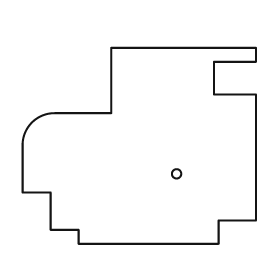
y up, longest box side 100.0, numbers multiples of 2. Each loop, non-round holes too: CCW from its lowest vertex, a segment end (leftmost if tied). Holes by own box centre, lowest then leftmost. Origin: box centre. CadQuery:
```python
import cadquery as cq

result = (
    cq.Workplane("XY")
    .moveTo(-26.0, -42.0)
    .lineTo(34.0, -42.0)
    .lineTo(34.0, -32.0)
    .lineTo(50.0, -32.0)
    .lineTo(50.0, 22.0)
    .lineTo(32.0, 22.0)
    .lineTo(32.0, 36.0)
    .lineTo(50.0, 36.0)
    .lineTo(50.0, 42.0)
    .lineTo(-12.0, 42.0)
    .lineTo(-12.0, 14.0)
    .lineTo(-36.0, 14.0)
    .threePointArc((-46.0, 10.0), (-50.0, 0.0))
    .lineTo(-50.0, -20.0)
    .lineTo(-38.0, -20.0)
    .lineTo(-38.0, -36.0)
    .lineTo(-26.0, -36.0)
    .close()
    .moveTo(16.0, -12.0)
    .circle(2.0)
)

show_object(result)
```